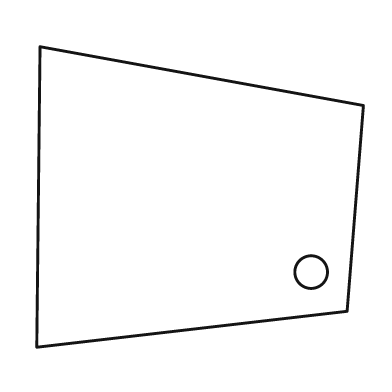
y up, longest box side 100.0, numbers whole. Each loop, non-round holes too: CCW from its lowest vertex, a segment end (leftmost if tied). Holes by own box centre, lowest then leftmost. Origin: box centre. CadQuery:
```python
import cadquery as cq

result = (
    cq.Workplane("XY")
    .moveTo(-50.0, -46.0)
    .lineTo(45.0, -35.0)
    .lineTo(50.0, 28.0)
    .lineTo(-49.0, 46.0)
    .close()
    .moveTo(34.0, -23.0)
    .circle(5.0)
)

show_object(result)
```